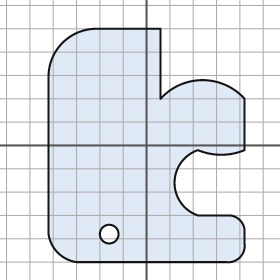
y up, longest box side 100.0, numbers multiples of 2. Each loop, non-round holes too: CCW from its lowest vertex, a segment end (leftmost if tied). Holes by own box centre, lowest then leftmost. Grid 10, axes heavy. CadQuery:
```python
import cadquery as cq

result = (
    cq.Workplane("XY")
    .moveTo(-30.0, -50.0)
    .lineTo(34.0, -50.0)
    .threePointArc((40.0, -48.0), (42.0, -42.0))
    .lineTo(42.0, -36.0)
    .threePointArc((40.0, -32.0), (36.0, -30.0))
    .lineTo(22.0, -30.0)
    .threePointArc((12.0, -16.0), (22.0, -2.0))
    .threePointArc((32.0, -4.0), (42.0, -2.0))
    .lineTo(42.0, 20.0)
    .threePointArc((24.0, 28.0), (6.0, 20.0))
    .lineTo(6.0, 50.0)
    .lineTo(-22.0, 50.0)
    .threePointArc((-36.0, 44.0), (-42.0, 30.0))
    .lineTo(-42.0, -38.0)
    .threePointArc((-38.0, -46.0), (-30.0, -50.0))
    .close()
    .moveTo(-16.0, -38.0)
    .circle(4.0)
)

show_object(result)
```